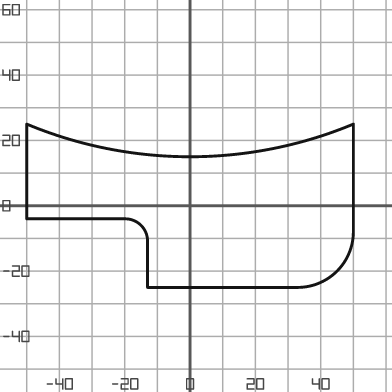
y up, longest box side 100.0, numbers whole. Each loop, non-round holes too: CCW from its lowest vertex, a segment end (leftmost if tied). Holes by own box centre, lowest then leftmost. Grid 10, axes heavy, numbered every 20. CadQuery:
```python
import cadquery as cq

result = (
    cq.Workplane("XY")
    .moveTo(-13.0, -25.0)
    .lineTo(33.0, -25.0)
    .threePointArc((45.0, -20.0), (50.0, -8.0))
    .lineTo(50.0, 25.0)
    .threePointArc((0.0, 15.0), (-50.0, 25.0))
    .lineTo(-50.0, -4.0)
    .lineTo(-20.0, -4.0)
    .threePointArc((-15.0, -6.0), (-13.0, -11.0))
    .close()
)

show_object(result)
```